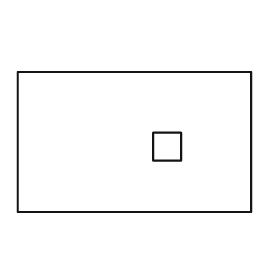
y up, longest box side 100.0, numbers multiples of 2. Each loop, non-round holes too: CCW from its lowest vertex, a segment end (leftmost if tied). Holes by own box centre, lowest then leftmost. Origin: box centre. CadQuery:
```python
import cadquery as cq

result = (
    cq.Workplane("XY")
    .moveTo(-50.0, -30.0)
    .lineTo(50.0, -30.0)
    .lineTo(50.0, 30.0)
    .lineTo(-50.0, 30.0)
    .close()
    .moveTo(8.0, -8.0)
    .lineTo(20.0, -8.0)
    .lineTo(20.0, 4.0)
    .lineTo(8.0, 4.0)
    .close()
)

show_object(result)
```